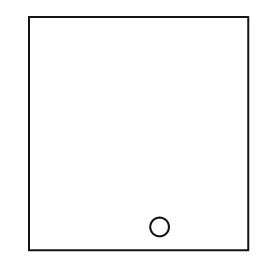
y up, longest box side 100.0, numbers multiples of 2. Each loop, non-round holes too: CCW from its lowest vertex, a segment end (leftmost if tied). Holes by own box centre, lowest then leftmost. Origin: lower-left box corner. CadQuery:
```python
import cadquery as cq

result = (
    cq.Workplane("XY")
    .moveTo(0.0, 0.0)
    .lineTo(94.0, 0.0)
    .lineTo(94.0, 100.0)
    .lineTo(0.0, 100.0)
    .close()
    .moveTo(56.0, 10.0)
    .circle(4.0)
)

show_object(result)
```